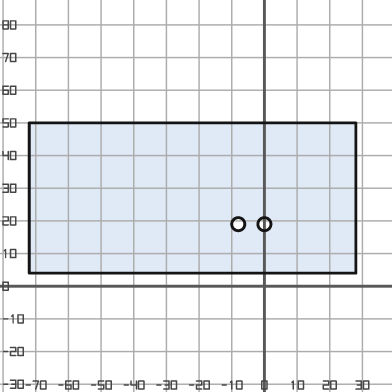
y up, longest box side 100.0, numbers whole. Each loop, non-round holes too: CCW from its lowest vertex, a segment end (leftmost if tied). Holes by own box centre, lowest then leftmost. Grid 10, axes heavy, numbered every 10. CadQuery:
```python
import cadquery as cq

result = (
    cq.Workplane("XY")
    .moveTo(-72.0, 4.0)
    .lineTo(28.0, 4.0)
    .lineTo(28.0, 50.0)
    .lineTo(-72.0, 50.0)
    .close()
    .moveTo(-8.0, 19.0)
    .circle(2.0)
    .moveTo(0.0, 19.0)
    .circle(2.0)
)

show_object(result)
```